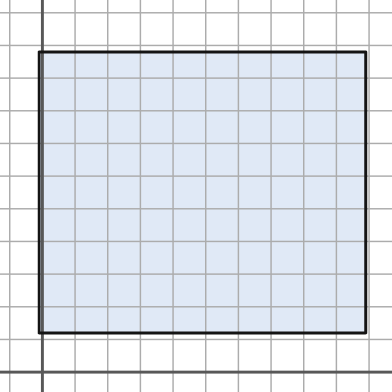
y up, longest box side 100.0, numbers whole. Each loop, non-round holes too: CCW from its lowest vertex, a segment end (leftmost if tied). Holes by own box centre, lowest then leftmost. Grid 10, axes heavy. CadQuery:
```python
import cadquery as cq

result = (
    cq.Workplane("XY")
    .moveTo(-1.0, 12.0)
    .lineTo(99.0, 12.0)
    .lineTo(99.0, 98.0)
    .lineTo(-1.0, 98.0)
    .close()
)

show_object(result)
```